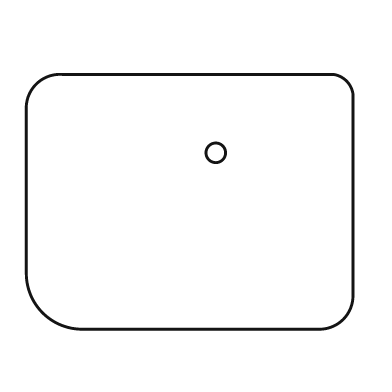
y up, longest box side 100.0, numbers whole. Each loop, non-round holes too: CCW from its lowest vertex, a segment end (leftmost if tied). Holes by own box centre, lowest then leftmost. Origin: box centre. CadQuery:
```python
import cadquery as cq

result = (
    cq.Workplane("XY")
    .moveTo(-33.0, -39.0)
    .lineTo(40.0, -39.0)
    .threePointArc((47.0, -36.0), (50.0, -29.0))
    .lineTo(50.0, 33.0)
    .threePointArc((48.0, 37.0), (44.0, 39.0))
    .lineTo(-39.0, 39.0)
    .threePointArc((-47.0, 36.0), (-50.0, 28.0))
    .lineTo(-50.0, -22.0)
    .threePointArc((-45.0, -34.0), (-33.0, -39.0))
    .close()
    .moveTo(8.0, 15.0)
    .circle(3.0)
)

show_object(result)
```